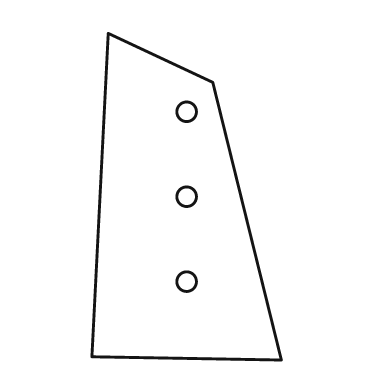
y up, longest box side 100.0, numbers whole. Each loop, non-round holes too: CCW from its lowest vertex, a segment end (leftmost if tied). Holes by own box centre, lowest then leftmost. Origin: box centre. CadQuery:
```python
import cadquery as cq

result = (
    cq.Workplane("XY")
    .moveTo(29.0, -50.0)
    .lineTo(8.0, 35.0)
    .lineTo(-24.0, 50.0)
    .lineTo(-29.0, -49.0)
    .close()
    .moveTo(0.0, -26.0)
    .circle(3.0)
    .moveTo(0.0, 0.0)
    .circle(3.0)
    .moveTo(0.0, 26.0)
    .circle(3.0)
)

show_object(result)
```